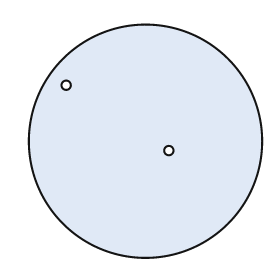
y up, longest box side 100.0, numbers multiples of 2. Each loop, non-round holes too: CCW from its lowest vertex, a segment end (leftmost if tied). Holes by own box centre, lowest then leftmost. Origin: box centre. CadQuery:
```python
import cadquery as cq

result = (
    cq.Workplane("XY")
    .moveTo(0.0, 0.0)
    .circle(50.0)
    .moveTo(10.0, -4.0)
    .circle(2.0)
    .moveTo(-34.0, 24.0)
    .circle(2.0)
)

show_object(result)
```